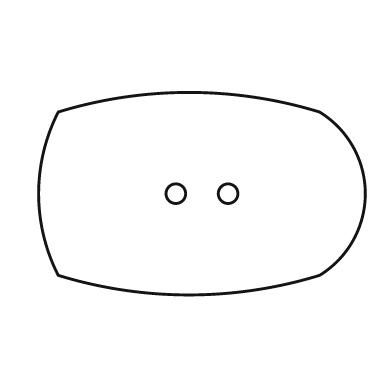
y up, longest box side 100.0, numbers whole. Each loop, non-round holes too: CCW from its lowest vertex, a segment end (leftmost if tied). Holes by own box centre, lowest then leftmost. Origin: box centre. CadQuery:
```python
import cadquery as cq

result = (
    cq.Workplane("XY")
    .moveTo(-44.0, -25.0)
    .threePointArc((-4.0, -31.0), (36.0, -25.0))
    .threePointArc((50.0, 0.0), (36.0, 25.0))
    .threePointArc((-4.0, 31.0), (-44.0, 25.0))
    .threePointArc((-50.0, 0.0), (-44.0, -25.0))
    .close()
    .moveTo(-8.0, 0.0)
    .circle(3.0)
    .moveTo(8.0, 0.0)
    .circle(3.0)
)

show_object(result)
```